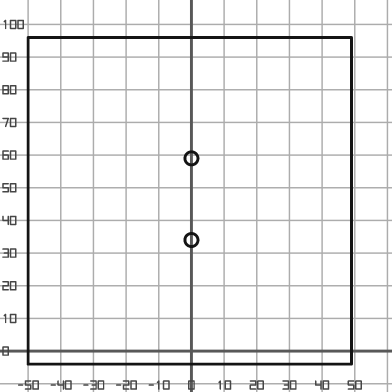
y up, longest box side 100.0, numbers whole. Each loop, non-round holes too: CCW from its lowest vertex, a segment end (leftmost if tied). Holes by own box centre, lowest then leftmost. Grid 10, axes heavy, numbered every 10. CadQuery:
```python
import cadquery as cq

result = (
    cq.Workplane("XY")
    .moveTo(-50.0, -4.0)
    .lineTo(49.0, -4.0)
    .lineTo(49.0, 96.0)
    .lineTo(-50.0, 96.0)
    .close()
    .moveTo(0.0, 34.0)
    .circle(2.0)
    .moveTo(0.0, 59.0)
    .circle(2.0)
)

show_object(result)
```